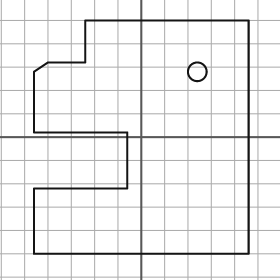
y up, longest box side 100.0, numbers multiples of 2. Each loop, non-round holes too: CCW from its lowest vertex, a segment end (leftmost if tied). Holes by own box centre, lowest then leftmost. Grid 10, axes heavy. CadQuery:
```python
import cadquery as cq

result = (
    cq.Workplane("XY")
    .moveTo(-46.0, -50.0)
    .lineTo(46.0, -50.0)
    .lineTo(46.0, 50.0)
    .lineTo(-24.0, 50.0)
    .lineTo(-24.0, 32.0)
    .lineTo(-40.0, 32.0)
    .lineTo(-46.0, 28.0)
    .lineTo(-46.0, 2.0)
    .lineTo(-6.0, 2.0)
    .lineTo(-6.0, -22.0)
    .lineTo(-46.0, -22.0)
    .close()
    .moveTo(24.0, 28.0)
    .circle(4.0)
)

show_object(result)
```